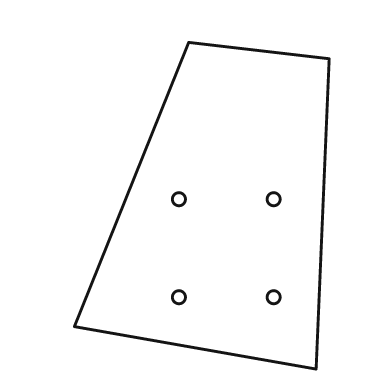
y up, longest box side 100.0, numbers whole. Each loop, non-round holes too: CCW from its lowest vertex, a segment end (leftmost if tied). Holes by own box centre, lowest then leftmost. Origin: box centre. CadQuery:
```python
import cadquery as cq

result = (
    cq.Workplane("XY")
    .moveTo(35.0, -50.0)
    .lineTo(39.0, 45.0)
    .lineTo(-4.0, 50.0)
    .lineTo(-39.0, -37.0)
    .close()
    .moveTo(-7.0, -28.0)
    .circle(2.0)
    .moveTo(22.0, -28.0)
    .circle(2.0)
    .moveTo(-7.0, 2.0)
    .circle(2.0)
    .moveTo(22.0, 2.0)
    .circle(2.0)
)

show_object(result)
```